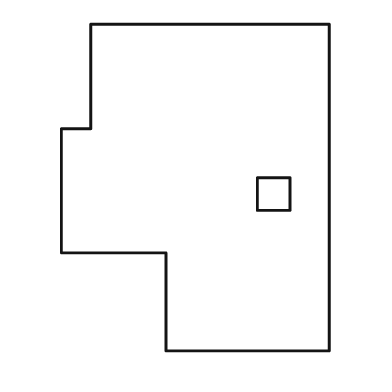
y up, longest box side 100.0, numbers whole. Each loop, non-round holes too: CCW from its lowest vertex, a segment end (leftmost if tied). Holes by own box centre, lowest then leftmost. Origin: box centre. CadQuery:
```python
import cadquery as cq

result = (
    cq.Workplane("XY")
    .moveTo(-9.0, -50.0)
    .lineTo(41.0, -50.0)
    .lineTo(41.0, 50.0)
    .lineTo(-32.0, 50.0)
    .lineTo(-32.0, 18.0)
    .lineTo(-41.0, 18.0)
    .lineTo(-41.0, -20.0)
    .lineTo(-9.0, -20.0)
    .close()
    .moveTo(19.0, -7.0)
    .lineTo(29.0, -7.0)
    .lineTo(29.0, 3.0)
    .lineTo(19.0, 3.0)
    .close()
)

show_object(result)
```